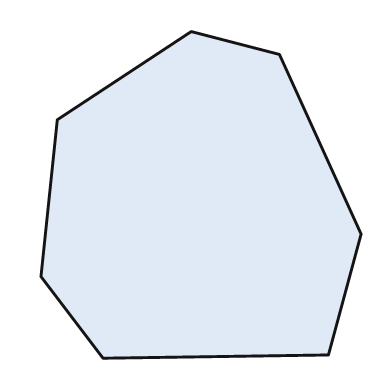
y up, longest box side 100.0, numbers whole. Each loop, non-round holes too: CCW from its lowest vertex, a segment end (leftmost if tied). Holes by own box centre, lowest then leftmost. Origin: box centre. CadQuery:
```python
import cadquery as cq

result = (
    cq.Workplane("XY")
    .moveTo(-30.0, -50.0)
    .lineTo(39.0, -49.0)
    .lineTo(49.0, -12.0)
    .lineTo(24.0, 43.0)
    .lineTo(-3.0, 50.0)
    .lineTo(-44.0, 23.0)
    .lineTo(-49.0, -25.0)
    .close()
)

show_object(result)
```